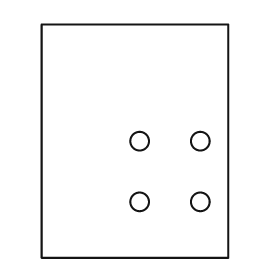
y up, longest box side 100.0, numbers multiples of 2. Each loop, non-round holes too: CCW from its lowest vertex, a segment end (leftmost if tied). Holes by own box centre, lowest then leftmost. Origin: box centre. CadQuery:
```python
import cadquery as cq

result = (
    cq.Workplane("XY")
    .moveTo(-40.0, -50.0)
    .lineTo(40.0, -50.0)
    .lineTo(40.0, 50.0)
    .lineTo(-40.0, 50.0)
    .close()
    .moveTo(2.0, -26.0)
    .circle(4.0)
    .moveTo(28.0, -26.0)
    .circle(4.0)
    .moveTo(2.0, 0.0)
    .circle(4.0)
    .moveTo(28.0, 0.0)
    .circle(4.0)
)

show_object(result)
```